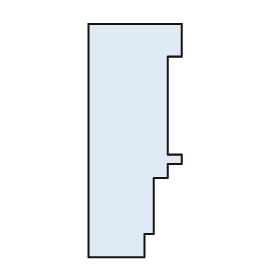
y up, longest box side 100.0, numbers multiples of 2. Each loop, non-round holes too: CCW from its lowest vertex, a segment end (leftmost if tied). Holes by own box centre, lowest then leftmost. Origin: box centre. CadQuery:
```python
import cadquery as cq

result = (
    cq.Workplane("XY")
    .moveTo(-20.0, -50.0)
    .lineTo(4.0, -50.0)
    .lineTo(4.0, -40.0)
    .lineTo(8.0, -40.0)
    .lineTo(8.0, -16.0)
    .lineTo(14.0, -16.0)
    .lineTo(14.0, -10.0)
    .lineTo(20.0, -10.0)
    .lineTo(20.0, -6.0)
    .lineTo(14.0, -6.0)
    .lineTo(14.0, 36.0)
    .lineTo(20.0, 36.0)
    .lineTo(20.0, 50.0)
    .lineTo(-20.0, 50.0)
    .close()
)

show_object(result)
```